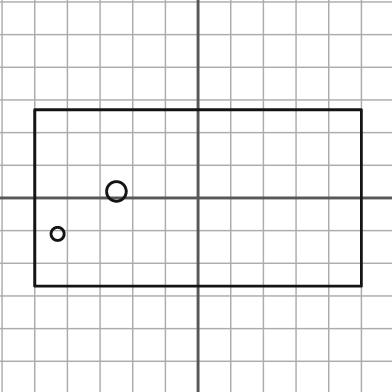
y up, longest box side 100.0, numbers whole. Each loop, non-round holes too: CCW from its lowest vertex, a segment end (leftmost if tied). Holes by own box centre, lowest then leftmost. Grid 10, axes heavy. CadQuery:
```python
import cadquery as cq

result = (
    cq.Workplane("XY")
    .moveTo(-50.0, -27.0)
    .lineTo(50.0, -27.0)
    .lineTo(50.0, 27.0)
    .lineTo(-50.0, 27.0)
    .close()
    .moveTo(-43.0, -11.0)
    .circle(2.0)
    .moveTo(-25.0, 2.0)
    .circle(3.0)
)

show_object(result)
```